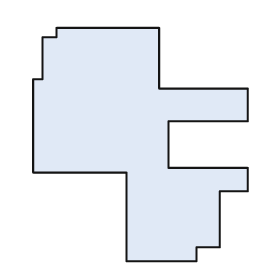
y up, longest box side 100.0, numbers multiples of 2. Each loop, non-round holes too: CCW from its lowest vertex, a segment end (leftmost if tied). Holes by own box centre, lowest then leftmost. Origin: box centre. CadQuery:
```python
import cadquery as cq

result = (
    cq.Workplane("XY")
    .moveTo(-6.0, -50.0)
    .lineTo(24.0, -50.0)
    .lineTo(24.0, -44.0)
    .lineTo(34.0, -44.0)
    .lineTo(34.0, -20.0)
    .lineTo(46.0, -20.0)
    .lineTo(46.0, -10.0)
    .lineTo(12.0, -10.0)
    .lineTo(12.0, 10.0)
    .lineTo(46.0, 10.0)
    .lineTo(46.0, 24.0)
    .lineTo(8.0, 24.0)
    .lineTo(8.0, 50.0)
    .lineTo(-36.0, 50.0)
    .lineTo(-36.0, 46.0)
    .lineTo(-42.0, 46.0)
    .lineTo(-42.0, 28.0)
    .lineTo(-46.0, 28.0)
    .lineTo(-46.0, -12.0)
    .lineTo(-6.0, -12.0)
    .close()
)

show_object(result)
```